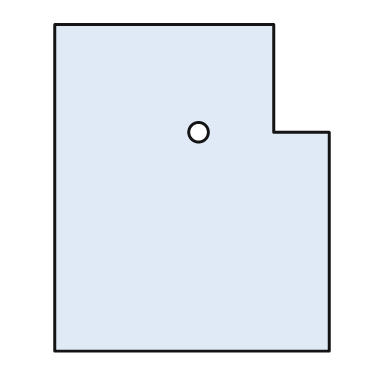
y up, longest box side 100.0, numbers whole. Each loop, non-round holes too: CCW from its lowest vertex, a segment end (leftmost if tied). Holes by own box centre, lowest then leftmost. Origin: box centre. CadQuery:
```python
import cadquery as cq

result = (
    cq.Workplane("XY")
    .moveTo(-42.0, -50.0)
    .lineTo(42.0, -50.0)
    .lineTo(42.0, 17.0)
    .lineTo(25.0, 17.0)
    .lineTo(25.0, 50.0)
    .lineTo(-42.0, 50.0)
    .close()
    .moveTo(2.0, 17.0)
    .circle(3.0)
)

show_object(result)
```